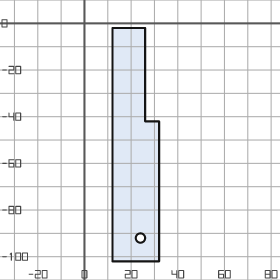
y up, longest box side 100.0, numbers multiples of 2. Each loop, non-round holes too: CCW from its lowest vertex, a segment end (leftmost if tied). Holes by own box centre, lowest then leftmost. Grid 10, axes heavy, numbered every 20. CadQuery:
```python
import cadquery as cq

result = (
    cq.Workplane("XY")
    .moveTo(12.0, -102.0)
    .lineTo(32.0, -102.0)
    .lineTo(32.0, -42.0)
    .lineTo(26.0, -42.0)
    .lineTo(26.0, -2.0)
    .lineTo(12.0, -2.0)
    .close()
    .moveTo(24.0, -92.0)
    .circle(2.0)
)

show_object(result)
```